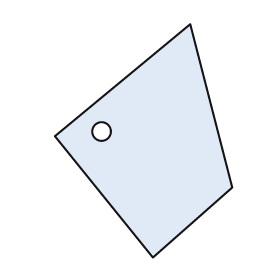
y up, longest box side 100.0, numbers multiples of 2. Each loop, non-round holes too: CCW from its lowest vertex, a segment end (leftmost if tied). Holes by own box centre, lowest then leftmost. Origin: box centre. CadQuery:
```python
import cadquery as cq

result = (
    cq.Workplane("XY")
    .moveTo(4.0, -50.0)
    .lineTo(38.0, -20.0)
    .lineTo(20.0, 50.0)
    .lineTo(-38.0, 2.0)
    .close()
    .moveTo(-18.0, 4.0)
    .circle(4.0)
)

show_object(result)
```